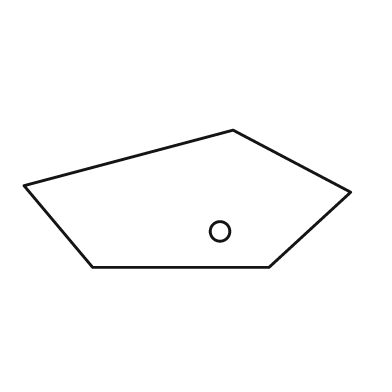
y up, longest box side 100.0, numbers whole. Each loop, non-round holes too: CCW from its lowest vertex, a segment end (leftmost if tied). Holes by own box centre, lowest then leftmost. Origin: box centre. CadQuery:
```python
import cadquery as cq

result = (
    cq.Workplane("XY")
    .moveTo(-29.0, -21.0)
    .lineTo(25.0, -21.0)
    .lineTo(50.0, 2.0)
    .lineTo(14.0, 21.0)
    .lineTo(-50.0, 4.0)
    .close()
    .moveTo(10.0, -10.0)
    .circle(3.0)
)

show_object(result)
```